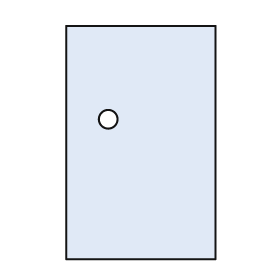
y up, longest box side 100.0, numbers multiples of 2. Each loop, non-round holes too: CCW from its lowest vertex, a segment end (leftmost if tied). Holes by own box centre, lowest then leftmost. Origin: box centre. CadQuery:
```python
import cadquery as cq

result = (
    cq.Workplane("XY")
    .moveTo(-32.0, -50.0)
    .lineTo(32.0, -50.0)
    .lineTo(32.0, 50.0)
    .lineTo(-32.0, 50.0)
    .close()
    .moveTo(-14.0, 10.0)
    .circle(4.0)
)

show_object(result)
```